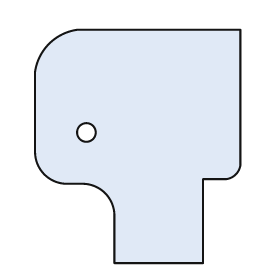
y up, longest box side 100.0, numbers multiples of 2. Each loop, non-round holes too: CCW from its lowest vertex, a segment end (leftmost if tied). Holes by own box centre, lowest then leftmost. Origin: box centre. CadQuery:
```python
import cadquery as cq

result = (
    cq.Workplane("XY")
    .moveTo(-10.0, -50.0)
    .lineTo(28.0, -50.0)
    .lineTo(28.0, -14.0)
    .lineTo(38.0, -14.0)
    .threePointArc((42.0, -12.0), (44.0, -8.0))
    .lineTo(44.0, 50.0)
    .lineTo(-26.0, 50.0)
    .threePointArc((-38.0, 44.0), (-44.0, 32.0))
    .lineTo(-44.0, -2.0)
    .threePointArc((-40.0, -12.0), (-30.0, -16.0))
    .lineTo(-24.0, -16.0)
    .threePointArc((-14.0, -20.0), (-10.0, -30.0))
    .close()
    .moveTo(-22.0, 6.0)
    .circle(4.0)
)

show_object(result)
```